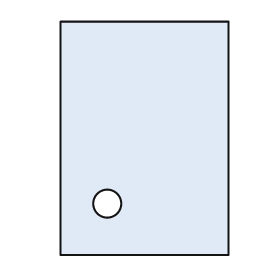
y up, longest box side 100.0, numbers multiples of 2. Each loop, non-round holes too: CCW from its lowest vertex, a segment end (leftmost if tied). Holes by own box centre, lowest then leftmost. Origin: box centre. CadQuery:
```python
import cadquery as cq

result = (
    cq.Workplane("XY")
    .moveTo(-36.0, -50.0)
    .lineTo(36.0, -50.0)
    .lineTo(36.0, 50.0)
    .lineTo(-36.0, 50.0)
    .close()
    .moveTo(-16.0, -28.0)
    .circle(6.0)
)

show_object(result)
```